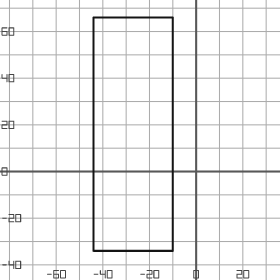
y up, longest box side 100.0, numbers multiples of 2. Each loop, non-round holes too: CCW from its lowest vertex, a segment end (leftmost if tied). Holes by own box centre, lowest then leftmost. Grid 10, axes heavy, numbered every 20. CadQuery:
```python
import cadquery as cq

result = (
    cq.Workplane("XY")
    .moveTo(-44.0, -34.0)
    .lineTo(-10.0, -34.0)
    .lineTo(-10.0, 66.0)
    .lineTo(-44.0, 66.0)
    .close()
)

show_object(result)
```